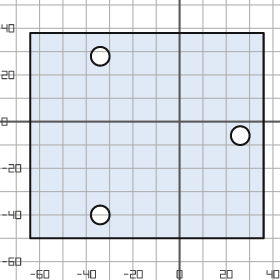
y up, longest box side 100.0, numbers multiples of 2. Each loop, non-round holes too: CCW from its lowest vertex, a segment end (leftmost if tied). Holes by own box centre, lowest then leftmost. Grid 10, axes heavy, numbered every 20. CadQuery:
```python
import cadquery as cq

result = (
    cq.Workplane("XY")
    .moveTo(-64.0, -50.0)
    .lineTo(36.0, -50.0)
    .lineTo(36.0, 38.0)
    .lineTo(-64.0, 38.0)
    .close()
    .moveTo(-34.0, -40.0)
    .circle(4.0)
    .moveTo(26.0, -6.0)
    .circle(4.0)
    .moveTo(-34.0, 28.0)
    .circle(4.0)
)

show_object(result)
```